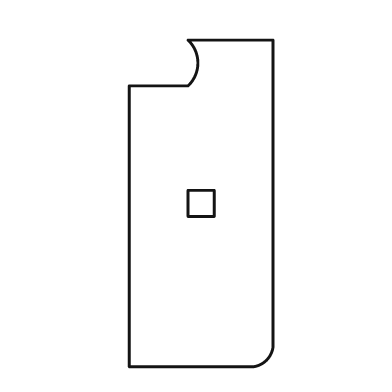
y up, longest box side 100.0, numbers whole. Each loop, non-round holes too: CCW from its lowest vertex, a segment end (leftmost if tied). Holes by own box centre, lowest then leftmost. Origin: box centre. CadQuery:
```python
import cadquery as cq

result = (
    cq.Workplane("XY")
    .moveTo(-22.0, -50.0)
    .lineTo(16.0, -50.0)
    .threePointArc((20.0, -48.0), (22.0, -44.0))
    .lineTo(22.0, 50.0)
    .lineTo(-4.0, 50.0)
    .threePointArc((-1.0, 43.0), (-4.0, 36.0))
    .lineTo(-22.0, 36.0)
    .close()
    .moveTo(-4.0, -4.0)
    .lineTo(4.0, -4.0)
    .lineTo(4.0, 4.0)
    .lineTo(-4.0, 4.0)
    .close()
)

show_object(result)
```